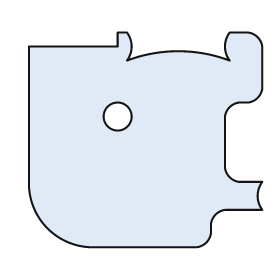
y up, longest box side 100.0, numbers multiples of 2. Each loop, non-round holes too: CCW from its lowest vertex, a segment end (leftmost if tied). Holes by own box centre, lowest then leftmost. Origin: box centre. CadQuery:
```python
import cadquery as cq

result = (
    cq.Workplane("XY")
    .moveTo(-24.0, -46.0)
    .lineTo(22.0, -46.0)
    .threePointArc((26.0, -44.0), (28.0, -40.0))
    .lineTo(28.0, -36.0)
    .threePointArc((30.0, -32.0), (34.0, -30.0))
    .lineTo(50.0, -30.0)
    .threePointArc((48.0, -24.0), (50.0, -18.0))
    .lineTo(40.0, -18.0)
    .threePointArc((36.0, -16.0), (34.0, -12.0))
    .lineTo(34.0, 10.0)
    .threePointArc((36.0, 14.0), (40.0, 16.0))
    .lineTo(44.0, 16.0)
    .threePointArc((48.0, 18.0), (50.0, 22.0))
    .lineTo(50.0, 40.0)
    .threePointArc((48.0, 44.0), (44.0, 46.0))
    .lineTo(36.0, 46.0)
    .threePointArc((34.0, 40.0), (36.0, 34.0))
    .threePointArc((14.0, 38.0), (-8.0, 34.0))
    .threePointArc((-6.0, 40.0), (-8.0, 46.0))
    .lineTo(-12.0, 46.0)
    .lineTo(-12.0, 40.0)
    .lineTo(-50.0, 40.0)
    .lineTo(-50.0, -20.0)
    .threePointArc((-42.0, -38.0), (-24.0, -46.0))
    .close()
    .moveTo(-12.0, 10.0)
    .circle(6.0)
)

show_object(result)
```